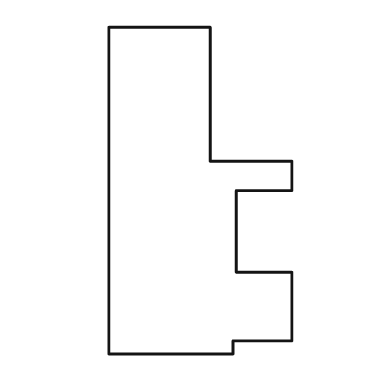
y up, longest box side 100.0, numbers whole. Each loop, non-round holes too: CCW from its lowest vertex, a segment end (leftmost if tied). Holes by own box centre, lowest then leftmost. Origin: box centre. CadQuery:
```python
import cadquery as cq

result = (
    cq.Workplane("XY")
    .moveTo(-28.0, -50.0)
    .lineTo(10.0, -50.0)
    .lineTo(10.0, -46.0)
    .lineTo(28.0, -46.0)
    .lineTo(28.0, -25.0)
    .lineTo(11.0, -25.0)
    .lineTo(11.0, 0.0)
    .lineTo(28.0, 0.0)
    .lineTo(28.0, 9.0)
    .lineTo(3.0, 9.0)
    .lineTo(3.0, 50.0)
    .lineTo(-28.0, 50.0)
    .close()
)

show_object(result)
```